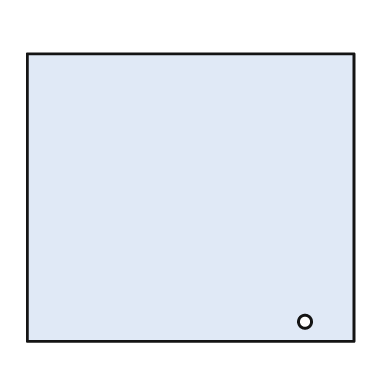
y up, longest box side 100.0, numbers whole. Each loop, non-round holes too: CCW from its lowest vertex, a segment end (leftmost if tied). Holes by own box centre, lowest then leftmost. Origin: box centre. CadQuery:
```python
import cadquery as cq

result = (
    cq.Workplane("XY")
    .moveTo(-50.0, -44.0)
    .lineTo(50.0, -44.0)
    .lineTo(50.0, 44.0)
    .lineTo(-50.0, 44.0)
    .close()
    .moveTo(35.0, -38.0)
    .circle(2.0)
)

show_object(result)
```